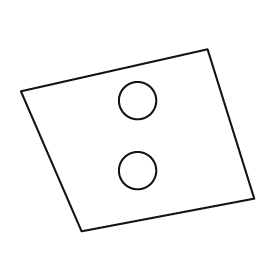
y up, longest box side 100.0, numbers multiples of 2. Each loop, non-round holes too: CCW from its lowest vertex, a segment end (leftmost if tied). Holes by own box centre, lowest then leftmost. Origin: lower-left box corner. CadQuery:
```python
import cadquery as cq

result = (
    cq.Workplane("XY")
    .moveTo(26.0, 0.0)
    .lineTo(100.0, 14.0)
    .lineTo(80.0, 78.0)
    .lineTo(0.0, 60.0)
    .close()
    .moveTo(50.0, 26.0)
    .circle(8.0)
    .moveTo(50.0, 56.0)
    .circle(8.0)
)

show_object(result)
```